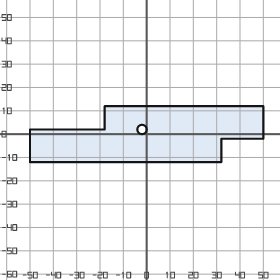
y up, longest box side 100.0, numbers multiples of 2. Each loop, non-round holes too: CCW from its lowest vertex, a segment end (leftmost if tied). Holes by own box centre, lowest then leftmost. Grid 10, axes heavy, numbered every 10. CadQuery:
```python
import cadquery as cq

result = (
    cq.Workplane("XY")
    .moveTo(-50.0, -12.0)
    .lineTo(32.0, -12.0)
    .lineTo(32.0, -2.0)
    .lineTo(50.0, -2.0)
    .lineTo(50.0, 12.0)
    .lineTo(-18.0, 12.0)
    .lineTo(-18.0, 2.0)
    .lineTo(-50.0, 2.0)
    .close()
    .moveTo(-2.0, 2.0)
    .circle(2.0)
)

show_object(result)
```